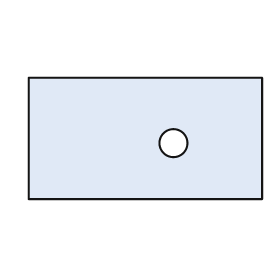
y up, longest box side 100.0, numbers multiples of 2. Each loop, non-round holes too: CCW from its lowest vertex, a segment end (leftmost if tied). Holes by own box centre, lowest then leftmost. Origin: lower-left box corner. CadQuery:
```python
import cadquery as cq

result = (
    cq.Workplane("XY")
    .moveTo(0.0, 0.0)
    .lineTo(100.0, 0.0)
    .lineTo(100.0, 52.0)
    .lineTo(0.0, 52.0)
    .close()
    .moveTo(62.0, 24.0)
    .circle(6.0)
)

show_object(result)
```